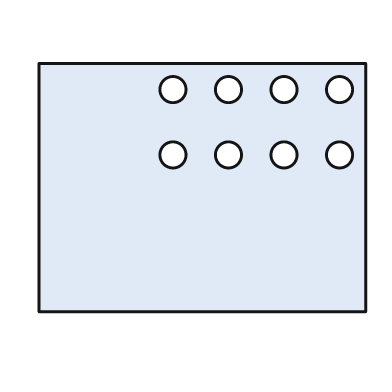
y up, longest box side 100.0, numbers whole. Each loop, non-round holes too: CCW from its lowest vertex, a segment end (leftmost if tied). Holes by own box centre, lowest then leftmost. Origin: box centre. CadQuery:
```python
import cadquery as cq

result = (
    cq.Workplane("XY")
    .moveTo(-50.0, -38.0)
    .lineTo(50.0, -38.0)
    .lineTo(50.0, 38.0)
    .lineTo(-50.0, 38.0)
    .close()
    .moveTo(-9.0, 10.0)
    .circle(4.0)
    .moveTo(8.0, 10.0)
    .circle(4.0)
    .moveTo(25.0, 10.0)
    .circle(4.0)
    .moveTo(42.0, 10.0)
    .circle(4.0)
    .moveTo(-9.0, 30.0)
    .circle(4.0)
    .moveTo(8.0, 30.0)
    .circle(4.0)
    .moveTo(25.0, 30.0)
    .circle(4.0)
    .moveTo(42.0, 30.0)
    .circle(4.0)
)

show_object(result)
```